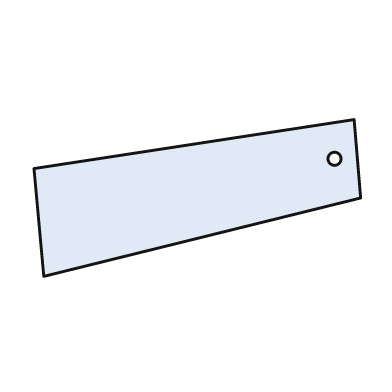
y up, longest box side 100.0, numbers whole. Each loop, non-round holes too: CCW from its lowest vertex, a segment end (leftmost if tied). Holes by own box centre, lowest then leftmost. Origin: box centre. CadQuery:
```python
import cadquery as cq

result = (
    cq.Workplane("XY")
    .moveTo(-47.0, -24.0)
    .lineTo(50.0, 0.0)
    .lineTo(48.0, 24.0)
    .lineTo(-50.0, 9.0)
    .close()
    .moveTo(42.0, 12.0)
    .circle(2.0)
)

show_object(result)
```